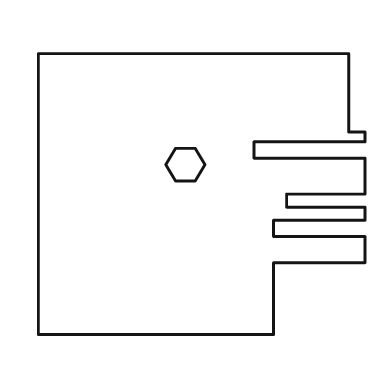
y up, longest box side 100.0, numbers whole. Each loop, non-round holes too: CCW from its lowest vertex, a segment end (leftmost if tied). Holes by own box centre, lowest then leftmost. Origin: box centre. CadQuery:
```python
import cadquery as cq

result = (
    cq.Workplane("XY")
    .moveTo(-50.0, -43.0)
    .lineTo(22.0, -43.0)
    .lineTo(22.0, -21.0)
    .lineTo(50.0, -21.0)
    .lineTo(50.0, -13.0)
    .lineTo(22.0, -13.0)
    .lineTo(22.0, -8.0)
    .lineTo(50.0, -8.0)
    .lineTo(50.0, -4.0)
    .lineTo(26.0, -4.0)
    .lineTo(26.0, 0.0)
    .lineTo(50.0, 0.0)
    .lineTo(50.0, 11.0)
    .lineTo(16.0, 11.0)
    .lineTo(16.0, 16.0)
    .lineTo(50.0, 16.0)
    .lineTo(50.0, 19.0)
    .lineTo(45.0, 19.0)
    .lineTo(45.0, 43.0)
    .lineTo(-50.0, 43.0)
    .close()
    .moveTo(-8.0, 4.0)
    .lineTo(-2.0, 4.0)
    .lineTo(1.0, 9.0)
    .lineTo(-2.0, 14.0)
    .lineTo(-8.0, 14.0)
    .lineTo(-11.0, 9.0)
    .close()
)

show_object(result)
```